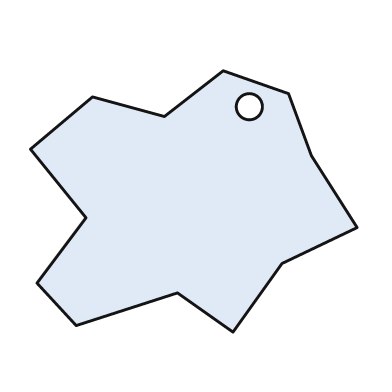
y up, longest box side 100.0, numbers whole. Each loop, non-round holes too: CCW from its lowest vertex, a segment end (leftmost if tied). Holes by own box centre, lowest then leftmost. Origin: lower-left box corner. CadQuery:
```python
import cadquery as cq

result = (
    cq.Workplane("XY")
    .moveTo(62.0, 0.0)
    .lineTo(77.0, 21.0)
    .lineTo(100.0, 32.0)
    .lineTo(86.0, 54.0)
    .lineTo(79.0, 73.0)
    .lineTo(59.0, 80.0)
    .lineTo(41.0, 66.0)
    .lineTo(19.0, 72.0)
    .lineTo(0.0, 56.0)
    .lineTo(17.0, 35.0)
    .lineTo(2.0, 15.0)
    .lineTo(14.0, 2.0)
    .lineTo(45.0, 12.0)
    .close()
    .moveTo(67.0, 69.0)
    .circle(4.0)
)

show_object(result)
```